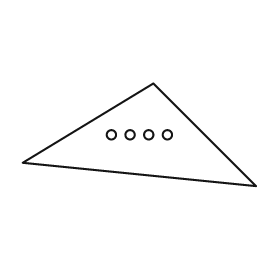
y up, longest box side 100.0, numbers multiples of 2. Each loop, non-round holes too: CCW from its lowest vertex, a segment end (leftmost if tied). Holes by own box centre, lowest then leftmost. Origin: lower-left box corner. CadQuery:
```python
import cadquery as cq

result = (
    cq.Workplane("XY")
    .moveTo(100.0, 0.0)
    .lineTo(56.0, 44.0)
    .lineTo(0.0, 10.0)
    .close()
    .moveTo(38.0, 22.0)
    .circle(2.0)
    .moveTo(46.0, 22.0)
    .circle(2.0)
    .moveTo(54.0, 22.0)
    .circle(2.0)
    .moveTo(62.0, 22.0)
    .circle(2.0)
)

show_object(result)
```